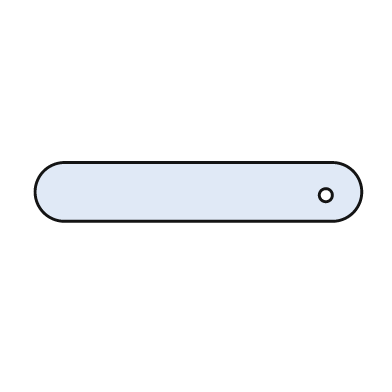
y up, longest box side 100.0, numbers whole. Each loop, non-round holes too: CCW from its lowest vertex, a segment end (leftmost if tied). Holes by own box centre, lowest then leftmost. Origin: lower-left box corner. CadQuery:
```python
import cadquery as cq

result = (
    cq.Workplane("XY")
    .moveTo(9.0, 0.0)
    .lineTo(91.0, 0.0)
    .threePointArc((100.0, 9.0), (91.0, 18.0))
    .lineTo(9.0, 18.0)
    .threePointArc((0.0, 9.0), (9.0, 0.0))
    .close()
    .moveTo(89.0, 8.0)
    .circle(2.0)
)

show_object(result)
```